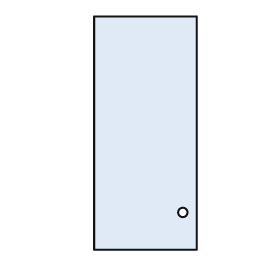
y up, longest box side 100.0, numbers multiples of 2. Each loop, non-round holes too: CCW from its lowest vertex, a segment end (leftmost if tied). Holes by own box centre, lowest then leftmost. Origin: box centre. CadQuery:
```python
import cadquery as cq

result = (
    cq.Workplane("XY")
    .moveTo(-22.0, -50.0)
    .lineTo(22.0, -50.0)
    .lineTo(22.0, 50.0)
    .lineTo(-22.0, 50.0)
    .close()
    .moveTo(16.0, -34.0)
    .circle(2.0)
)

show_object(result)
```